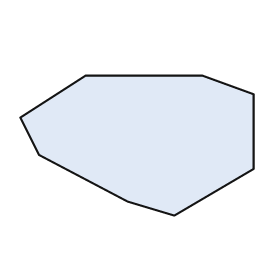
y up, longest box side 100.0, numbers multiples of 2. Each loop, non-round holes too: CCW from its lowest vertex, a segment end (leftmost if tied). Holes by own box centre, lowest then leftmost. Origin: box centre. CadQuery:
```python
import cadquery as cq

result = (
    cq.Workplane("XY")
    .moveTo(16.0, -30.0)
    .lineTo(50.0, -10.0)
    .lineTo(50.0, 22.0)
    .lineTo(28.0, 30.0)
    .lineTo(-22.0, 30.0)
    .lineTo(-50.0, 12.0)
    .lineTo(-42.0, -4.0)
    .lineTo(-4.0, -24.0)
    .close()
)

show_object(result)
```